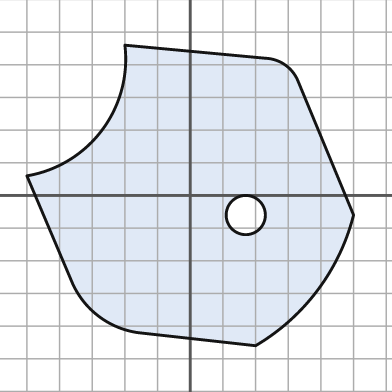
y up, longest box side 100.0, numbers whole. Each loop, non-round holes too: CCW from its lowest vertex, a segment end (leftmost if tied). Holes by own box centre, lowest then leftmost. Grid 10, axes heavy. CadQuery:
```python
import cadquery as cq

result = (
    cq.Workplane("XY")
    .moveTo(20.0, -46.0)
    .threePointArc((39.0, -29.0), (50.0, -6.0))
    .lineTo(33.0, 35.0)
    .threePointArc((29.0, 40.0), (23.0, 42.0))
    .lineTo(-20.0, 46.0)
    .threePointArc((-27.0, 20.0), (-50.0, 6.0))
    .lineTo(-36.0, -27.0)
    .threePointArc((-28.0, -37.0), (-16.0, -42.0))
    .close()
    .moveTo(17.0, -6.0)
    .circle(6.0)
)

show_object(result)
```